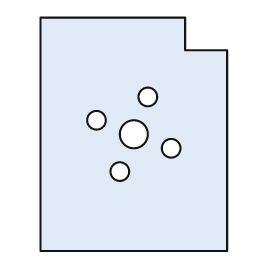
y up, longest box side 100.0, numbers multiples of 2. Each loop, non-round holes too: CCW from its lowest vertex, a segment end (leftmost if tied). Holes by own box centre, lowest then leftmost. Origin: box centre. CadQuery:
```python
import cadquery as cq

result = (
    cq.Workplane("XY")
    .moveTo(-40.0, -50.0)
    .lineTo(40.0, -50.0)
    .lineTo(40.0, 36.0)
    .lineTo(22.0, 36.0)
    .lineTo(22.0, 50.0)
    .lineTo(-40.0, 50.0)
    .close()
    .moveTo(-6.0, -16.0)
    .circle(4.0)
    .moveTo(16.0, -6.0)
    .circle(4.0)
    .moveTo(0.0, 0.0)
    .circle(6.0)
    .moveTo(-16.0, 6.0)
    .circle(4.0)
    .moveTo(6.0, 16.0)
    .circle(4.0)
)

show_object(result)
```